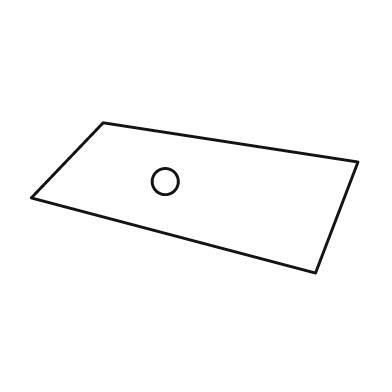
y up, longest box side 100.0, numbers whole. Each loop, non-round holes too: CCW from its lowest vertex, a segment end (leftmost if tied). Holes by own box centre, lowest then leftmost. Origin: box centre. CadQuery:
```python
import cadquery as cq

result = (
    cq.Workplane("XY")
    .moveTo(37.0, -23.0)
    .lineTo(50.0, 11.0)
    .lineTo(-28.0, 23.0)
    .lineTo(-50.0, 0.0)
    .close()
    .moveTo(-9.0, 5.0)
    .circle(4.0)
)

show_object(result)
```